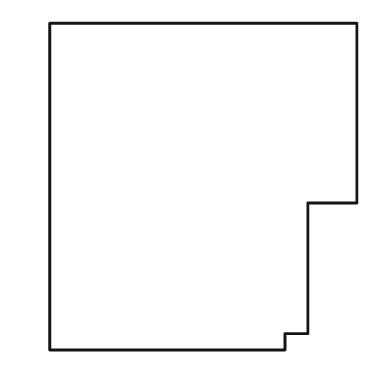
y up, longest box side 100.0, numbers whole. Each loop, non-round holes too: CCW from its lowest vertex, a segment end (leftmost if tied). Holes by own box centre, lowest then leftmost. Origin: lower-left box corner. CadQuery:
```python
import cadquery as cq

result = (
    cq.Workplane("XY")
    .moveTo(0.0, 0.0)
    .lineTo(72.0, 0.0)
    .lineTo(72.0, 5.0)
    .lineTo(79.0, 5.0)
    .lineTo(79.0, 45.0)
    .lineTo(94.0, 45.0)
    .lineTo(94.0, 100.0)
    .lineTo(0.0, 100.0)
    .close()
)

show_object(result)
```